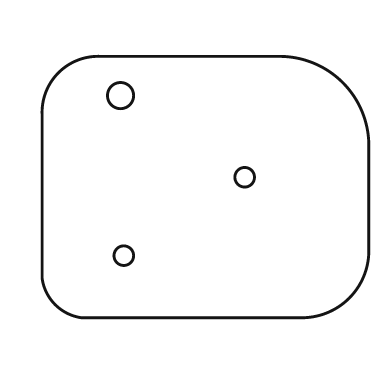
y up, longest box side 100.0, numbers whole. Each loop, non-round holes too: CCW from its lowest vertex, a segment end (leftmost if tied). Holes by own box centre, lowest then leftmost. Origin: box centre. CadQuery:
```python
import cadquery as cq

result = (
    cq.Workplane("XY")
    .moveTo(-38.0, -40.0)
    .lineTo(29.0, -40.0)
    .threePointArc((44.0, -34.0), (50.0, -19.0))
    .lineTo(50.0, 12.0)
    .threePointArc((42.0, 32.0), (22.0, 40.0))
    .lineTo(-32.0, 40.0)
    .threePointArc((-45.0, 35.0), (-50.0, 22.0))
    .lineTo(-50.0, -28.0)
    .threePointArc((-46.0, -36.0), (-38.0, -40.0))
    .close()
    .moveTo(-25.0, -21.0)
    .circle(3.0)
    .moveTo(12.0, 3.0)
    .circle(3.0)
    .moveTo(-26.0, 28.0)
    .circle(4.0)
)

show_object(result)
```